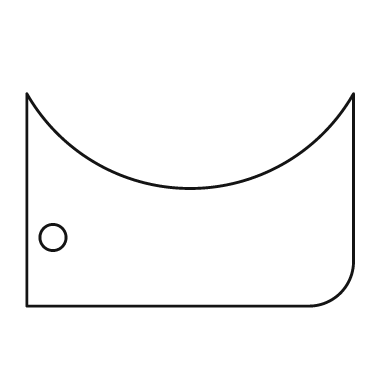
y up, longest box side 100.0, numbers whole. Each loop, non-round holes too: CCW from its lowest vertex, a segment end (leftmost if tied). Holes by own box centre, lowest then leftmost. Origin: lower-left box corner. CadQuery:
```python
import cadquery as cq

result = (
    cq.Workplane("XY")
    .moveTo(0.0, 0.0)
    .lineTo(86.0, 0.0)
    .threePointArc((96.0, 4.0), (100.0, 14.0))
    .lineTo(100.0, 65.0)
    .threePointArc((50.0, 36.0), (0.0, 65.0))
    .close()
    .moveTo(8.0, 21.0)
    .circle(4.0)
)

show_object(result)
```